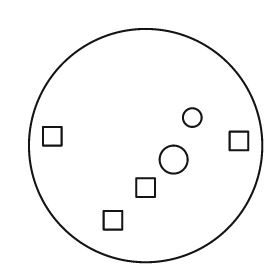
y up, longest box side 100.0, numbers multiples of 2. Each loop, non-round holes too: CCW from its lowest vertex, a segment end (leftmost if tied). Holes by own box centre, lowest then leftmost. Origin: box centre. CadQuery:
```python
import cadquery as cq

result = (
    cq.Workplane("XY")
    .moveTo(0.0, 0.0)
    .circle(50.0)
    .moveTo(-18.0, -36.0)
    .lineTo(-10.0, -36.0)
    .lineTo(-10.0, -28.0)
    .lineTo(-18.0, -28.0)
    .close()
    .moveTo(-4.0, -22.0)
    .lineTo(4.0, -22.0)
    .lineTo(4.0, -14.0)
    .lineTo(-4.0, -14.0)
    .close()
    .moveTo(12.0, -6.0)
    .circle(6.0)
    .moveTo(36.0, -2.0)
    .lineTo(44.0, -2.0)
    .lineTo(44.0, 6.0)
    .lineTo(36.0, 6.0)
    .close()
    .moveTo(-44.0, 0.0)
    .lineTo(-36.0, 0.0)
    .lineTo(-36.0, 8.0)
    .lineTo(-44.0, 8.0)
    .close()
    .moveTo(20.0, 12.0)
    .circle(4.0)
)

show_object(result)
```